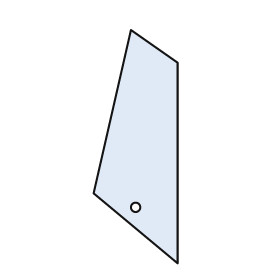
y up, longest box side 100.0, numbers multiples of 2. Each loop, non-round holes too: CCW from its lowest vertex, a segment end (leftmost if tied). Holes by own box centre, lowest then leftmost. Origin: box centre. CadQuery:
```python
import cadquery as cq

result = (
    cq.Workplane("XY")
    .moveTo(18.0, -50.0)
    .lineTo(18.0, 36.0)
    .lineTo(-2.0, 50.0)
    .lineTo(-18.0, -20.0)
    .close()
    .moveTo(0.0, -26.0)
    .circle(2.0)
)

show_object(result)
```